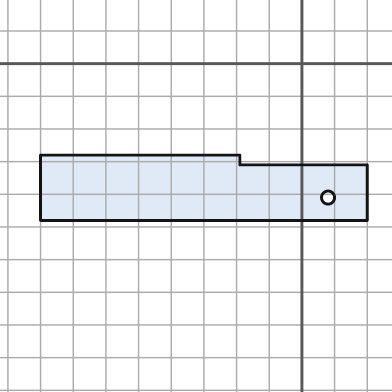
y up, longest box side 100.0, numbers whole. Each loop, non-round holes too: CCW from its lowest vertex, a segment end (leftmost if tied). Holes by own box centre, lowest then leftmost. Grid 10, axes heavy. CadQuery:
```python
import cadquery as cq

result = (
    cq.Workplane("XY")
    .moveTo(-80.0, -48.0)
    .lineTo(20.0, -48.0)
    .lineTo(20.0, -31.0)
    .lineTo(-19.0, -31.0)
    .lineTo(-19.0, -28.0)
    .lineTo(-80.0, -28.0)
    .close()
    .moveTo(8.0, -41.0)
    .circle(2.0)
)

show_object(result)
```